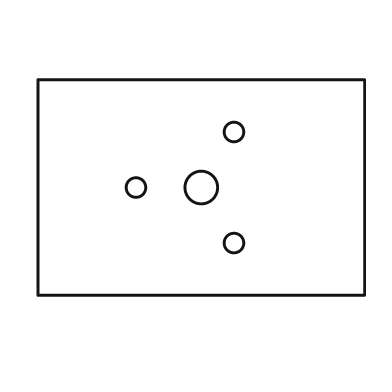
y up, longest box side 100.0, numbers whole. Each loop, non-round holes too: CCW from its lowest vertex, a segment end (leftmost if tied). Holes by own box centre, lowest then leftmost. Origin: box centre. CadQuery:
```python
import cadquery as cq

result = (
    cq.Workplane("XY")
    .moveTo(-50.0, -33.0)
    .lineTo(50.0, -33.0)
    .lineTo(50.0, 33.0)
    .lineTo(-50.0, 33.0)
    .close()
    .moveTo(10.0, -17.0)
    .circle(3.0)
    .moveTo(-20.0, 0.0)
    .circle(3.0)
    .moveTo(0.0, 0.0)
    .circle(5.0)
    .moveTo(10.0, 17.0)
    .circle(3.0)
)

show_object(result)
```